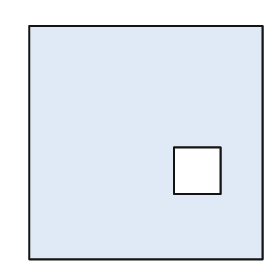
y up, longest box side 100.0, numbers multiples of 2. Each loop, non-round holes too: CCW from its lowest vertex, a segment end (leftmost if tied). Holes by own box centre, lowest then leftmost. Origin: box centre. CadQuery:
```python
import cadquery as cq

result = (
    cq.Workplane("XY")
    .moveTo(-50.0, -50.0)
    .lineTo(50.0, -50.0)
    .lineTo(50.0, 50.0)
    .lineTo(-50.0, 50.0)
    .close()
    .moveTo(12.0, -22.0)
    .lineTo(32.0, -22.0)
    .lineTo(32.0, -2.0)
    .lineTo(12.0, -2.0)
    .close()
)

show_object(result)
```